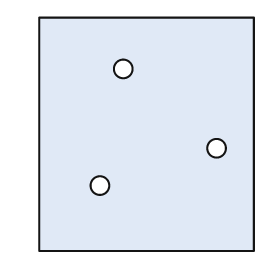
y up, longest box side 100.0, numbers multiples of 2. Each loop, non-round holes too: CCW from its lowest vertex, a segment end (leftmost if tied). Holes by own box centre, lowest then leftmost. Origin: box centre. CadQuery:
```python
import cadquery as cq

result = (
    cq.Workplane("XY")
    .moveTo(-46.0, -50.0)
    .lineTo(46.0, -50.0)
    .lineTo(46.0, 50.0)
    .lineTo(-46.0, 50.0)
    .close()
    .moveTo(-20.0, -22.0)
    .circle(4.0)
    .moveTo(30.0, -6.0)
    .circle(4.0)
    .moveTo(-10.0, 28.0)
    .circle(4.0)
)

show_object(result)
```